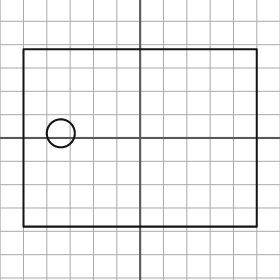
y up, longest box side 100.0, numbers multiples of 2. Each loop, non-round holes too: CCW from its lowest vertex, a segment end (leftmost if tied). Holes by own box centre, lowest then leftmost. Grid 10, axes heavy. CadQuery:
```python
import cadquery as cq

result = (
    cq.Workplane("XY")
    .moveTo(-50.0, -38.0)
    .lineTo(50.0, -38.0)
    .lineTo(50.0, 38.0)
    .lineTo(-50.0, 38.0)
    .close()
    .moveTo(-34.0, 2.0)
    .circle(6.0)
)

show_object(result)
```